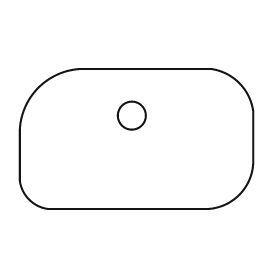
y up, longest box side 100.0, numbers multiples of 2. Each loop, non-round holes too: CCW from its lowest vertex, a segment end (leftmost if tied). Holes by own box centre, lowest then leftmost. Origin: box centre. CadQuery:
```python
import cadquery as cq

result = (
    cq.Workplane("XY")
    .moveTo(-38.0, -30.0)
    .lineTo(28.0, -30.0)
    .threePointArc((44.0, -24.0), (50.0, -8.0))
    .lineTo(50.0, 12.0)
    .threePointArc((44.0, 24.0), (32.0, 30.0))
    .lineTo(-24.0, 30.0)
    .threePointArc((-42.0, 22.0), (-50.0, 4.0))
    .lineTo(-50.0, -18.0)
    .threePointArc((-46.0, -26.0), (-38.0, -30.0))
    .close()
    .moveTo(-2.0, 10.0)
    .circle(6.0)
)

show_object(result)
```